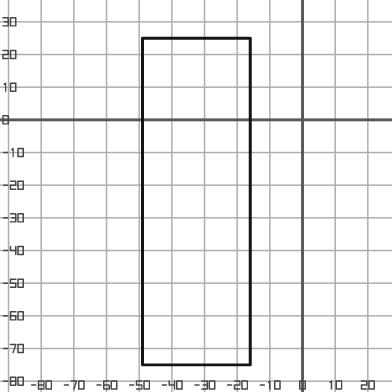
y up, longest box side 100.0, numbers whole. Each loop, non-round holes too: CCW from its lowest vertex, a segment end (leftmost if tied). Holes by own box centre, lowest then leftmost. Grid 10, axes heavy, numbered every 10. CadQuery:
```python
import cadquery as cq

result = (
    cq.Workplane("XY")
    .moveTo(-49.0, -75.0)
    .lineTo(-16.0, -75.0)
    .lineTo(-16.0, 25.0)
    .lineTo(-49.0, 25.0)
    .close()
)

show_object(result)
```